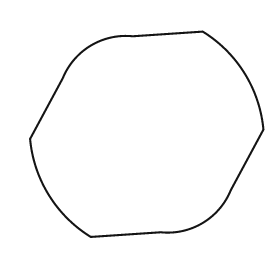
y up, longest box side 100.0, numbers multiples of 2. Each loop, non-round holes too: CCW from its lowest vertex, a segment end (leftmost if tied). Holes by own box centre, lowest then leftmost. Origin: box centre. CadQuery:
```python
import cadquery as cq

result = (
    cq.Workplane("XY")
    .moveTo(-24.0, -44.0)
    .lineTo(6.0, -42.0)
    .threePointArc((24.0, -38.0), (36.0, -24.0))
    .lineTo(50.0, 2.0)
    .threePointArc((42.0, 26.0), (24.0, 44.0))
    .lineTo(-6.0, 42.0)
    .threePointArc((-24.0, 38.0), (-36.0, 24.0))
    .lineTo(-50.0, -2.0)
    .threePointArc((-42.0, -26.0), (-24.0, -44.0))
    .close()
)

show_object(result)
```